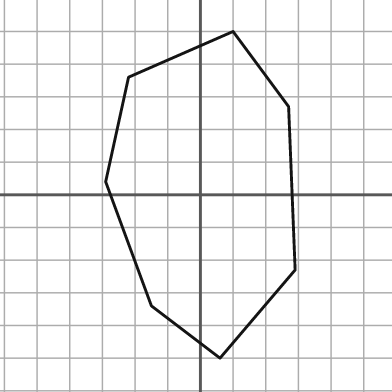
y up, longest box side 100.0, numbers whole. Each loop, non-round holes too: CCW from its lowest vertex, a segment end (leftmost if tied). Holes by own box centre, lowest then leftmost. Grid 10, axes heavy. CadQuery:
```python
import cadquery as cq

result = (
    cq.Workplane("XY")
    .moveTo(6.0, -50.0)
    .lineTo(29.0, -23.0)
    .lineTo(27.0, 27.0)
    .lineTo(10.0, 50.0)
    .lineTo(-22.0, 36.0)
    .lineTo(-29.0, 4.0)
    .lineTo(-15.0, -34.0)
    .close()
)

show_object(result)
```